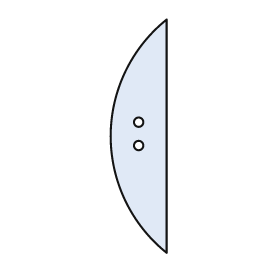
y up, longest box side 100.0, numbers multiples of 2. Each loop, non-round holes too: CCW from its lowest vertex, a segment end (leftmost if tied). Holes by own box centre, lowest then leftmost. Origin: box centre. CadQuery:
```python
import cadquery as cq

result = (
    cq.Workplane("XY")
    .moveTo(12.0, -50.0)
    .lineTo(12.0, 50.0)
    .threePointArc((-12.0, 0.0), (12.0, -50.0))
    .close()
    .moveTo(0.0, -4.0)
    .circle(2.0)
    .moveTo(0.0, 6.0)
    .circle(2.0)
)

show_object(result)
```